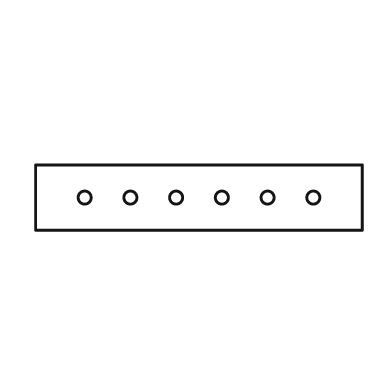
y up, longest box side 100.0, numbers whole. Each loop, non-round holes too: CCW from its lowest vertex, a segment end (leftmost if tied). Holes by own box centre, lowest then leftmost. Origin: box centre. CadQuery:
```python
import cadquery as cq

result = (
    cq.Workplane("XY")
    .moveTo(-50.0, -10.0)
    .lineTo(50.0, -10.0)
    .lineTo(50.0, 10.0)
    .lineTo(-50.0, 10.0)
    .close()
    .moveTo(-35.0, 0.0)
    .circle(2.0)
    .moveTo(-21.0, 0.0)
    .circle(2.0)
    .moveTo(-7.0, 0.0)
    .circle(2.0)
    .moveTo(7.0, 0.0)
    .circle(2.0)
    .moveTo(21.0, 0.0)
    .circle(2.0)
    .moveTo(35.0, 0.0)
    .circle(2.0)
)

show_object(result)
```